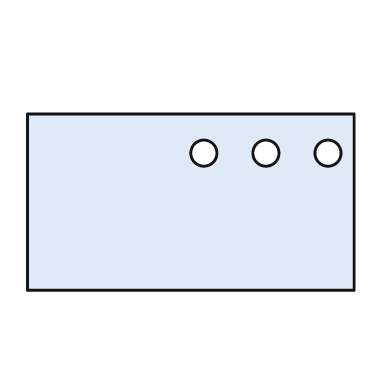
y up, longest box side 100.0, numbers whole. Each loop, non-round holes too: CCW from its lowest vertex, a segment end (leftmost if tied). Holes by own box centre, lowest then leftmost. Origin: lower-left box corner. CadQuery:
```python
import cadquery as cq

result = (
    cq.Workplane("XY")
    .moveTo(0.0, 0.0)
    .lineTo(100.0, 0.0)
    .lineTo(100.0, 54.0)
    .lineTo(0.0, 54.0)
    .close()
    .moveTo(54.0, 42.0)
    .circle(4.0)
    .moveTo(73.0, 42.0)
    .circle(4.0)
    .moveTo(92.0, 42.0)
    .circle(4.0)
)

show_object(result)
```